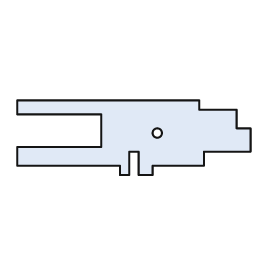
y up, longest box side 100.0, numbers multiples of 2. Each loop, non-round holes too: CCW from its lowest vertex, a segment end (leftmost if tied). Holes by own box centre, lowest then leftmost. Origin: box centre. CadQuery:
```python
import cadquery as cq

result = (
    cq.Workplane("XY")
    .moveTo(-6.0, -16.0)
    .lineTo(-2.0, -16.0)
    .lineTo(-2.0, -6.0)
    .lineTo(2.0, -6.0)
    .lineTo(2.0, -16.0)
    .lineTo(8.0, -16.0)
    .lineTo(8.0, -12.0)
    .lineTo(30.0, -12.0)
    .lineTo(30.0, -6.0)
    .lineTo(50.0, -6.0)
    .lineTo(50.0, 4.0)
    .lineTo(44.0, 4.0)
    .lineTo(44.0, 12.0)
    .lineTo(28.0, 12.0)
    .lineTo(28.0, 16.0)
    .lineTo(-50.0, 16.0)
    .lineTo(-50.0, 10.0)
    .lineTo(-14.0, 10.0)
    .lineTo(-14.0, -4.0)
    .lineTo(-50.0, -4.0)
    .lineTo(-50.0, -12.0)
    .lineTo(-6.0, -12.0)
    .close()
    .moveTo(10.0, 2.0)
    .circle(2.0)
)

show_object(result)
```